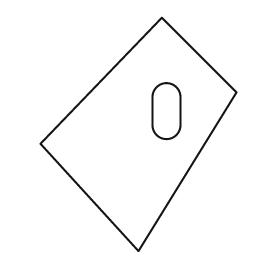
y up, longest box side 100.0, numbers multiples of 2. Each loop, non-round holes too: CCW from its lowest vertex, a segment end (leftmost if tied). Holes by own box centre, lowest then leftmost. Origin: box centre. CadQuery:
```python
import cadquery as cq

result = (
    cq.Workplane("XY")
    .moveTo(0.0, -50.0)
    .lineTo(42.0, 18.0)
    .lineTo(10.0, 50.0)
    .lineTo(-42.0, -4.0)
    .close()
    .moveTo(6.0, 4.0)
    .threePointArc((12.0, -2.0), (18.0, 4.0))
    .lineTo(18.0, 16.0)
    .threePointArc((12.0, 22.0), (6.0, 16.0))
    .close()
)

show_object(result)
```